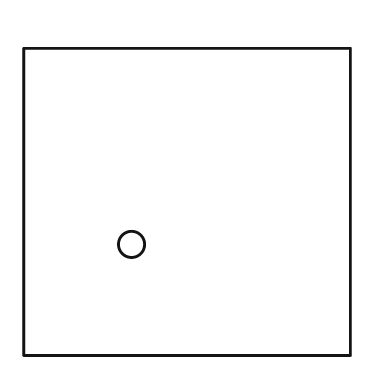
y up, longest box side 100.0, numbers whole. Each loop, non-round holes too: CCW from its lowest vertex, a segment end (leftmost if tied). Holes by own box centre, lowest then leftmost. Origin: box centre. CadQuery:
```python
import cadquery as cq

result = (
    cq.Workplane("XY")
    .moveTo(-50.0, -47.0)
    .lineTo(50.0, -47.0)
    .lineTo(50.0, 47.0)
    .lineTo(-50.0, 47.0)
    .close()
    .moveTo(-17.0, -13.0)
    .circle(4.0)
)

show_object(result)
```